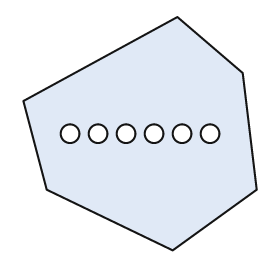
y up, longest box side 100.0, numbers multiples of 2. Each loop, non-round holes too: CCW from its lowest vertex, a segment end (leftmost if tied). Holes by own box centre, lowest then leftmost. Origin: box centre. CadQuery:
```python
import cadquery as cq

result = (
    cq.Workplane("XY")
    .moveTo(14.0, -50.0)
    .lineTo(50.0, -24.0)
    .lineTo(44.0, 26.0)
    .lineTo(16.0, 50.0)
    .lineTo(-50.0, 14.0)
    .lineTo(-40.0, -24.0)
    .close()
    .moveTo(-30.0, 0.0)
    .circle(4.0)
    .moveTo(-18.0, 0.0)
    .circle(4.0)
    .moveTo(-6.0, 0.0)
    .circle(4.0)
    .moveTo(6.0, 0.0)
    .circle(4.0)
    .moveTo(18.0, 0.0)
    .circle(4.0)
    .moveTo(30.0, 0.0)
    .circle(4.0)
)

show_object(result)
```